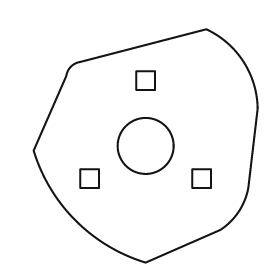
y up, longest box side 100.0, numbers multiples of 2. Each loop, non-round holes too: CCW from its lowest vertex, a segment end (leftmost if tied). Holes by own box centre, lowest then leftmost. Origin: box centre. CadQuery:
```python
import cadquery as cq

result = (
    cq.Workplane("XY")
    .moveTo(0.0, -50.0)
    .lineTo(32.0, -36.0)
    .threePointArc((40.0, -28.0), (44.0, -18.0))
    .lineTo(48.0, 16.0)
    .threePointArc((42.0, 36.0), (26.0, 50.0))
    .lineTo(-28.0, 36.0)
    .threePointArc((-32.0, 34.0), (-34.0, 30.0))
    .lineTo(-48.0, -2.0)
    .threePointArc((-30.0, -32.0), (0.0, -50.0))
    .close()
    .moveTo(-28.0, -18.0)
    .lineTo(-20.0, -18.0)
    .lineTo(-20.0, -10.0)
    .lineTo(-28.0, -10.0)
    .close()
    .moveTo(20.0, -18.0)
    .lineTo(28.0, -18.0)
    .lineTo(28.0, -10.0)
    .lineTo(20.0, -10.0)
    .close()
    .moveTo(0.0, 0.0)
    .circle(12.0)
    .moveTo(-4.0, 24.0)
    .lineTo(4.0, 24.0)
    .lineTo(4.0, 32.0)
    .lineTo(-4.0, 32.0)
    .close()
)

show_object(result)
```